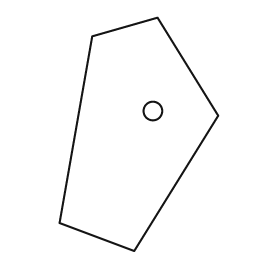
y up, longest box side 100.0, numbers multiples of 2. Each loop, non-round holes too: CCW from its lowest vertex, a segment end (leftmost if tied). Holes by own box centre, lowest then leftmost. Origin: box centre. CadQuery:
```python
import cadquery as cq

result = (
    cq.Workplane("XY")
    .moveTo(-2.0, -50.0)
    .lineTo(34.0, 8.0)
    .lineTo(8.0, 50.0)
    .lineTo(-20.0, 42.0)
    .lineTo(-34.0, -38.0)
    .close()
    .moveTo(6.0, 10.0)
    .circle(4.0)
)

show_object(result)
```